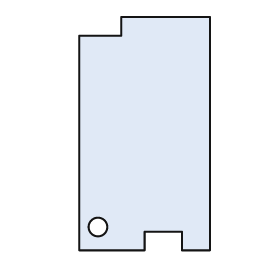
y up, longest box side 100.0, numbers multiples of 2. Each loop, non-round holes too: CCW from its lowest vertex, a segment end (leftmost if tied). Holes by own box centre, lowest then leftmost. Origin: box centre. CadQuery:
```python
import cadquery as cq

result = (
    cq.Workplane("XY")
    .moveTo(-28.0, -50.0)
    .lineTo(0.0, -50.0)
    .lineTo(0.0, -42.0)
    .lineTo(16.0, -42.0)
    .lineTo(16.0, -50.0)
    .lineTo(28.0, -50.0)
    .lineTo(28.0, 50.0)
    .lineTo(-10.0, 50.0)
    .lineTo(-10.0, 42.0)
    .lineTo(-28.0, 42.0)
    .close()
    .moveTo(-20.0, -40.0)
    .circle(4.0)
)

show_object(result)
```